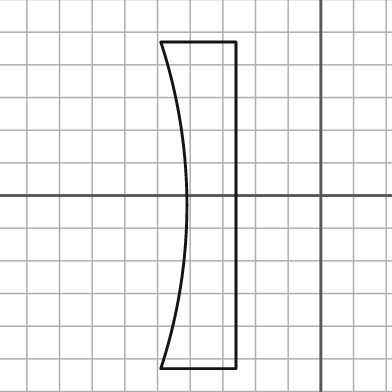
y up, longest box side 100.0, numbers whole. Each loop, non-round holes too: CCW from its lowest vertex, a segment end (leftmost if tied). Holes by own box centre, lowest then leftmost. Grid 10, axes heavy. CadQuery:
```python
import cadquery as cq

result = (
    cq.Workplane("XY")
    .moveTo(-49.0, -53.0)
    .lineTo(-26.0, -53.0)
    .lineTo(-26.0, 47.0)
    .lineTo(-49.0, 47.0)
    .threePointArc((-41.0, -3.0), (-49.0, -53.0))
    .close()
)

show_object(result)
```